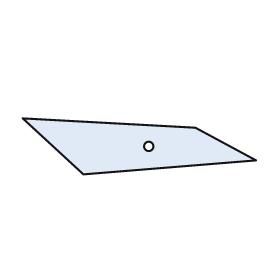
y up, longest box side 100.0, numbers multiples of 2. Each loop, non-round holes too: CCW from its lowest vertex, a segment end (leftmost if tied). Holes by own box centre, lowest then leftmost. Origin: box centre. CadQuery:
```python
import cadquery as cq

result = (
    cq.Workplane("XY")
    .moveTo(-24.0, -12.0)
    .lineTo(50.0, -6.0)
    .lineTo(24.0, 8.0)
    .lineTo(-50.0, 12.0)
    .close()
    .moveTo(4.0, 0.0)
    .circle(2.0)
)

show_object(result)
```